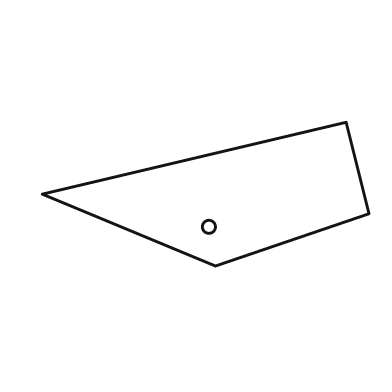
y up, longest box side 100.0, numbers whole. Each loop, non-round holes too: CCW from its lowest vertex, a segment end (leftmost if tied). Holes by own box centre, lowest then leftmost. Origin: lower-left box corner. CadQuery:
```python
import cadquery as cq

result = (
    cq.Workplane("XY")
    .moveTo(53.0, 0.0)
    .lineTo(100.0, 16.0)
    .lineTo(93.0, 44.0)
    .lineTo(0.0, 22.0)
    .close()
    .moveTo(51.0, 12.0)
    .circle(2.0)
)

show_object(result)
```